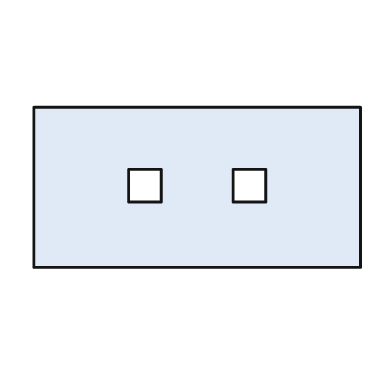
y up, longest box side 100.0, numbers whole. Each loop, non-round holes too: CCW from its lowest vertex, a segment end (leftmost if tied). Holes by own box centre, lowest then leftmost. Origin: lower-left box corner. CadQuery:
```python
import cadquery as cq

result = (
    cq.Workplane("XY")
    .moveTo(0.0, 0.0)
    .lineTo(100.0, 0.0)
    .lineTo(100.0, 49.0)
    .lineTo(0.0, 49.0)
    .close()
    .moveTo(29.0, 20.0)
    .lineTo(39.0, 20.0)
    .lineTo(39.0, 30.0)
    .lineTo(29.0, 30.0)
    .close()
    .moveTo(61.0, 20.0)
    .lineTo(71.0, 20.0)
    .lineTo(71.0, 30.0)
    .lineTo(61.0, 30.0)
    .close()
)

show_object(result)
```